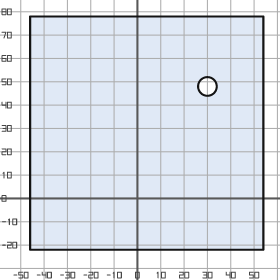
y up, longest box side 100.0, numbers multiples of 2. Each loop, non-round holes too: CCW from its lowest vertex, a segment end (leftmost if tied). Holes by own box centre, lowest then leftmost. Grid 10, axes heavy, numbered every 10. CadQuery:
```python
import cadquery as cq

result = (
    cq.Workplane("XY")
    .moveTo(-46.0, -22.0)
    .lineTo(54.0, -22.0)
    .lineTo(54.0, 78.0)
    .lineTo(-46.0, 78.0)
    .close()
    .moveTo(30.0, 48.0)
    .circle(4.0)
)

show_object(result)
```